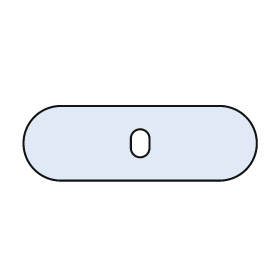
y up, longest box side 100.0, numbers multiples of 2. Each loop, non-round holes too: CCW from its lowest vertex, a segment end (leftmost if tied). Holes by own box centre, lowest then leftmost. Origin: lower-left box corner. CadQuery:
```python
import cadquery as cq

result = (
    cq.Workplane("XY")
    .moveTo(16.0, 0.0)
    .lineTo(84.0, 0.0)
    .threePointArc((100.0, 16.0), (84.0, 32.0))
    .lineTo(16.0, 32.0)
    .threePointArc((0.0, 16.0), (16.0, 0.0))
    .close()
    .moveTo(46.0, 14.0)
    .threePointArc((50.0, 10.0), (54.0, 14.0))
    .lineTo(54.0, 18.0)
    .threePointArc((50.0, 22.0), (46.0, 18.0))
    .close()
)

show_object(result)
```